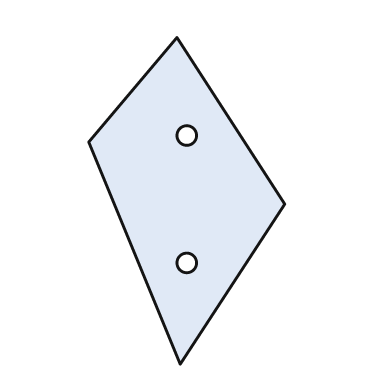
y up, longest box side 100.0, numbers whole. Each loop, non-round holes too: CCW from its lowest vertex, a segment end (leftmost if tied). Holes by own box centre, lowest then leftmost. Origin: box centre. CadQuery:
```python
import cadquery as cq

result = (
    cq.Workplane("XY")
    .moveTo(-2.0, -50.0)
    .lineTo(30.0, -1.0)
    .lineTo(-3.0, 50.0)
    .lineTo(-30.0, 18.0)
    .close()
    .moveTo(0.0, -19.0)
    .circle(3.0)
    .moveTo(0.0, 20.0)
    .circle(3.0)
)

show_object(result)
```